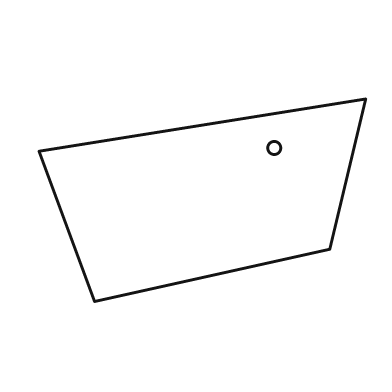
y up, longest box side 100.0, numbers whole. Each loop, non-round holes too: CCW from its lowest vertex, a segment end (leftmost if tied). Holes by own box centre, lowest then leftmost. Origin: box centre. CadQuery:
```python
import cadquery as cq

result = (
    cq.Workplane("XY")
    .moveTo(-33.0, -31.0)
    .lineTo(39.0, -15.0)
    .lineTo(50.0, 31.0)
    .lineTo(-50.0, 15.0)
    .close()
    .moveTo(22.0, 16.0)
    .circle(2.0)
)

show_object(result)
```